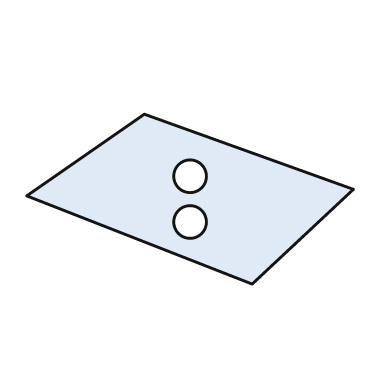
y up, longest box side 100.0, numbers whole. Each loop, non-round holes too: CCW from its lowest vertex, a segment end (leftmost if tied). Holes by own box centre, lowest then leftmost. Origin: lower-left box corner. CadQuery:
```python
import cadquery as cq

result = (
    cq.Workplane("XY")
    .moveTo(69.0, 0.0)
    .lineTo(100.0, 29.0)
    .lineTo(36.0, 52.0)
    .lineTo(0.0, 27.0)
    .close()
    .moveTo(50.0, 19.0)
    .circle(5.0)
    .moveTo(50.0, 33.0)
    .circle(5.0)
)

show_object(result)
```